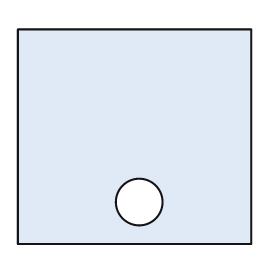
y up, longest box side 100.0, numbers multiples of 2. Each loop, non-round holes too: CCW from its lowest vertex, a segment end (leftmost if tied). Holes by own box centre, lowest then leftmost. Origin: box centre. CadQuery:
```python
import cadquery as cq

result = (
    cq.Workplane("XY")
    .moveTo(-50.0, -46.0)
    .lineTo(50.0, -46.0)
    .lineTo(50.0, 46.0)
    .lineTo(-50.0, 46.0)
    .close()
    .moveTo(2.0, -28.0)
    .circle(10.0)
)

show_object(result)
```